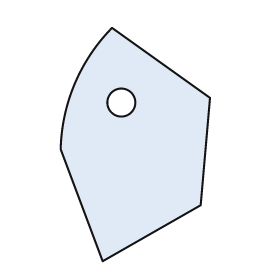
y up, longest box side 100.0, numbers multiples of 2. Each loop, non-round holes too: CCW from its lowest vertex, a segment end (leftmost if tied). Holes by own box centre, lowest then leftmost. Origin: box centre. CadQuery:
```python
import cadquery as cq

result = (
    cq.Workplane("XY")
    .moveTo(-14.0, -50.0)
    .lineTo(28.0, -26.0)
    .lineTo(32.0, 20.0)
    .lineTo(-10.0, 50.0)
    .threePointArc((-26.0, 26.0), (-32.0, -2.0))
    .close()
    .moveTo(-6.0, 18.0)
    .circle(6.0)
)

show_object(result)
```